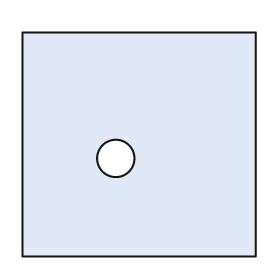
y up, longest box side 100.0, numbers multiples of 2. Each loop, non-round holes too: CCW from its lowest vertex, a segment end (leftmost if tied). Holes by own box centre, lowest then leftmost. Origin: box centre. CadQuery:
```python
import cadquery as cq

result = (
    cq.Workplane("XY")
    .moveTo(-50.0, -48.0)
    .lineTo(50.0, -48.0)
    .lineTo(50.0, 48.0)
    .lineTo(-50.0, 48.0)
    .close()
    .moveTo(-10.0, -6.0)
    .circle(8.0)
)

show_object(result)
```